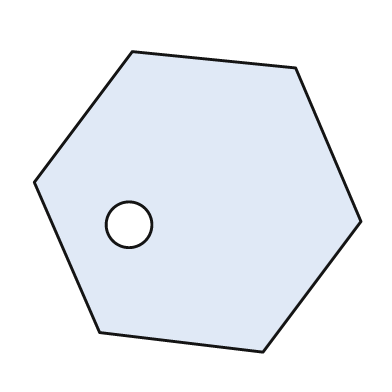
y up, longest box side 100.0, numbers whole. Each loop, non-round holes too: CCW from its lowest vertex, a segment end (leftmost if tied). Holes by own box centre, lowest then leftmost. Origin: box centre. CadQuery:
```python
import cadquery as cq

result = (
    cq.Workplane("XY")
    .moveTo(20.0, -46.0)
    .lineTo(50.0, -6.0)
    .lineTo(30.0, 41.0)
    .lineTo(-20.0, 46.0)
    .lineTo(-50.0, 6.0)
    .lineTo(-30.0, -40.0)
    .close()
    .moveTo(-21.0, -7.0)
    .circle(7.0)
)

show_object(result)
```